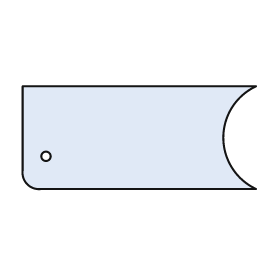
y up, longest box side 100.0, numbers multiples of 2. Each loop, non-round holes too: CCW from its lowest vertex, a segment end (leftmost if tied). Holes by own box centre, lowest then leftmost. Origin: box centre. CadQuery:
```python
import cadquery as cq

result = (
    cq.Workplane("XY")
    .moveTo(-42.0, -22.0)
    .lineTo(50.0, -22.0)
    .threePointArc((36.0, 0.0), (50.0, 22.0))
    .lineTo(-50.0, 22.0)
    .lineTo(-50.0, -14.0)
    .threePointArc((-48.0, -20.0), (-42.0, -22.0))
    .close()
    .moveTo(-40.0, -8.0)
    .circle(2.0)
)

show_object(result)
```